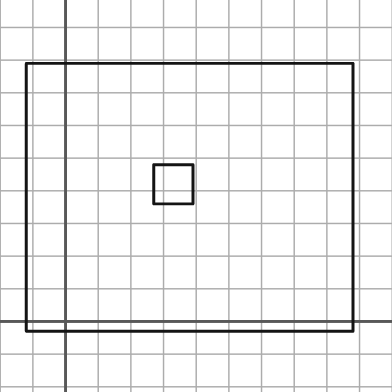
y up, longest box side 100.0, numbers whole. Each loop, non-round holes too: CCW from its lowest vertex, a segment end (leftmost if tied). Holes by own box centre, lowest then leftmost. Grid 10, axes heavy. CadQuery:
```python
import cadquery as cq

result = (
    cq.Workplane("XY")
    .moveTo(-12.0, -3.0)
    .lineTo(88.0, -3.0)
    .lineTo(88.0, 79.0)
    .lineTo(-12.0, 79.0)
    .close()
    .moveTo(27.0, 36.0)
    .lineTo(39.0, 36.0)
    .lineTo(39.0, 48.0)
    .lineTo(27.0, 48.0)
    .close()
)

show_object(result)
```